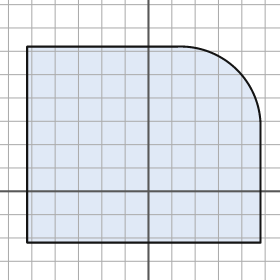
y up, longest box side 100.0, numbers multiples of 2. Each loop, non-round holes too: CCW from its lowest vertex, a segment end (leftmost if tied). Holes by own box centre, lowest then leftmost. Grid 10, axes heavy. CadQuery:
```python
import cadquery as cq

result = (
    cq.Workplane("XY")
    .moveTo(-52.0, -22.0)
    .lineTo(48.0, -22.0)
    .lineTo(48.0, 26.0)
    .threePointArc((38.0, 52.0), (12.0, 62.0))
    .lineTo(-52.0, 62.0)
    .close()
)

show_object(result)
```